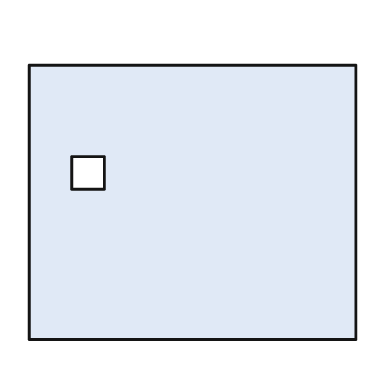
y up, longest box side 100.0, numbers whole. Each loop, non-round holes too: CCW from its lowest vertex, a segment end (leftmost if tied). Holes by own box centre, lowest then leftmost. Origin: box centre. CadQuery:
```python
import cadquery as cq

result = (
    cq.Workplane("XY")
    .moveTo(-50.0, -42.0)
    .lineTo(50.0, -42.0)
    .lineTo(50.0, 42.0)
    .lineTo(-50.0, 42.0)
    .close()
    .moveTo(-37.0, 4.0)
    .lineTo(-27.0, 4.0)
    .lineTo(-27.0, 14.0)
    .lineTo(-37.0, 14.0)
    .close()
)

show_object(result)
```